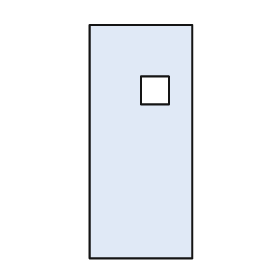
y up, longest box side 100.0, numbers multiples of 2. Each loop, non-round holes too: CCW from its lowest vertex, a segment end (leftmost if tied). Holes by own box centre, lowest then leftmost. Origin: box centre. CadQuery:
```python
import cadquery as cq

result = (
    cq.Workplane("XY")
    .moveTo(-22.0, -50.0)
    .lineTo(22.0, -50.0)
    .lineTo(22.0, 50.0)
    .lineTo(-22.0, 50.0)
    .close()
    .moveTo(0.0, 16.0)
    .lineTo(12.0, 16.0)
    .lineTo(12.0, 28.0)
    .lineTo(0.0, 28.0)
    .close()
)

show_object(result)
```